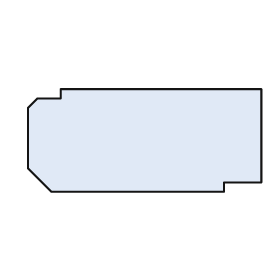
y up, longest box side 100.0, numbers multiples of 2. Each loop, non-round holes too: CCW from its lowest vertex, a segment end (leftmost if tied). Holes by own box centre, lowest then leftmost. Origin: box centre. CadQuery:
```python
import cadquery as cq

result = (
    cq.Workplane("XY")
    .moveTo(-40.0, -22.0)
    .lineTo(34.0, -22.0)
    .lineTo(34.0, -18.0)
    .lineTo(50.0, -18.0)
    .lineTo(50.0, 22.0)
    .lineTo(-36.0, 22.0)
    .lineTo(-36.0, 18.0)
    .lineTo(-46.0, 18.0)
    .lineTo(-50.0, 14.0)
    .lineTo(-50.0, -12.0)
    .close()
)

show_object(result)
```